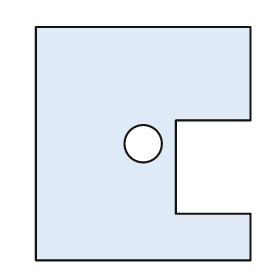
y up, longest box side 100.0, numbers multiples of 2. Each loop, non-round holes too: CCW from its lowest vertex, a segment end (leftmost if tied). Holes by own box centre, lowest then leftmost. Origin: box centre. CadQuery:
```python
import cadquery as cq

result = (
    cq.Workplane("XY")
    .moveTo(-46.0, -50.0)
    .lineTo(46.0, -50.0)
    .lineTo(46.0, -30.0)
    .lineTo(14.0, -30.0)
    .lineTo(14.0, 10.0)
    .lineTo(46.0, 10.0)
    .lineTo(46.0, 50.0)
    .lineTo(-46.0, 50.0)
    .close()
    .moveTo(0.0, 0.0)
    .circle(8.0)
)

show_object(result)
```